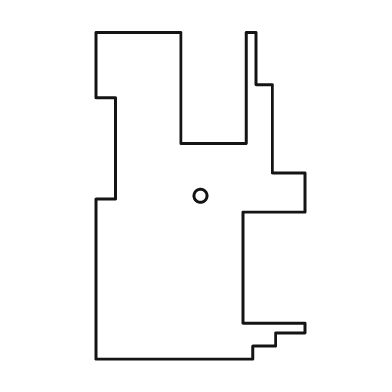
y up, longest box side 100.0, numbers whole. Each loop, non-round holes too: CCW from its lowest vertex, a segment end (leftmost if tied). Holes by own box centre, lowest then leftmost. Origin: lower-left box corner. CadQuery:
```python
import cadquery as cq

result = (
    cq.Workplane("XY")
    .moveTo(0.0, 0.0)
    .lineTo(48.0, 0.0)
    .lineTo(48.0, 4.0)
    .lineTo(55.0, 4.0)
    .lineTo(55.0, 8.0)
    .lineTo(64.0, 8.0)
    .lineTo(64.0, 11.0)
    .lineTo(45.0, 11.0)
    .lineTo(45.0, 45.0)
    .lineTo(64.0, 45.0)
    .lineTo(64.0, 57.0)
    .lineTo(54.0, 57.0)
    .lineTo(54.0, 84.0)
    .lineTo(49.0, 84.0)
    .lineTo(49.0, 100.0)
    .lineTo(46.0, 100.0)
    .lineTo(46.0, 66.0)
    .lineTo(26.0, 66.0)
    .lineTo(26.0, 100.0)
    .lineTo(0.0, 100.0)
    .lineTo(0.0, 80.0)
    .lineTo(6.0, 80.0)
    .lineTo(6.0, 49.0)
    .lineTo(0.0, 49.0)
    .close()
    .moveTo(32.0, 50.0)
    .circle(2.0)
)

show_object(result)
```